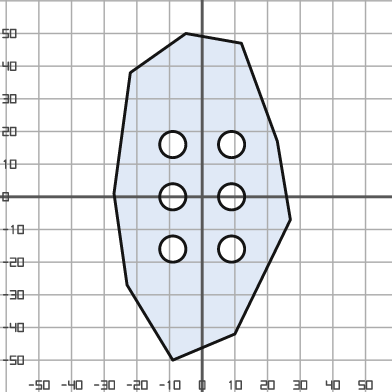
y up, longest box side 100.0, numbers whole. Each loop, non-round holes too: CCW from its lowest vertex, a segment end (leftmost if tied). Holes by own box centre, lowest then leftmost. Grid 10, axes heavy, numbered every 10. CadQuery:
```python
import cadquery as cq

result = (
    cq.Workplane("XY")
    .moveTo(-9.0, -50.0)
    .lineTo(10.0, -42.0)
    .lineTo(27.0, -7.0)
    .lineTo(23.0, 17.0)
    .lineTo(12.0, 47.0)
    .lineTo(-5.0, 50.0)
    .lineTo(-22.0, 38.0)
    .lineTo(-27.0, 1.0)
    .lineTo(-23.0, -27.0)
    .close()
    .moveTo(-9.0, -16.0)
    .circle(4.0)
    .moveTo(9.0, -16.0)
    .circle(4.0)
    .moveTo(-9.0, 0.0)
    .circle(4.0)
    .moveTo(9.0, 0.0)
    .circle(4.0)
    .moveTo(-9.0, 16.0)
    .circle(4.0)
    .moveTo(9.0, 16.0)
    .circle(4.0)
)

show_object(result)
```